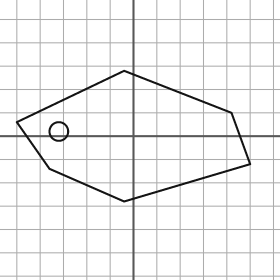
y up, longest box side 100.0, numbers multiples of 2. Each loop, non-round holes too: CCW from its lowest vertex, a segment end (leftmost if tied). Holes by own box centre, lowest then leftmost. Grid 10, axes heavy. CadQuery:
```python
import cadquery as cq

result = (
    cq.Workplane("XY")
    .moveTo(-4.0, -28.0)
    .lineTo(50.0, -12.0)
    .lineTo(42.0, 10.0)
    .lineTo(-4.0, 28.0)
    .lineTo(-50.0, 6.0)
    .lineTo(-36.0, -14.0)
    .close()
    .moveTo(-32.0, 2.0)
    .circle(4.0)
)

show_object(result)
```